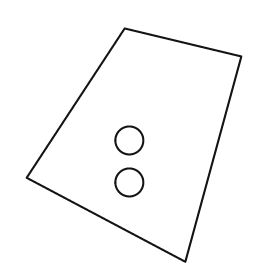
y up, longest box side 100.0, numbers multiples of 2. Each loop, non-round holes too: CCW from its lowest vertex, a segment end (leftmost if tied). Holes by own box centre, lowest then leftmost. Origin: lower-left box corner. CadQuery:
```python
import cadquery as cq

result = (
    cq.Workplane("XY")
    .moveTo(68.0, 0.0)
    .lineTo(92.0, 88.0)
    .lineTo(42.0, 100.0)
    .lineTo(0.0, 36.0)
    .close()
    .moveTo(44.0, 34.0)
    .circle(6.0)
    .moveTo(44.0, 52.0)
    .circle(6.0)
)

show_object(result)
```